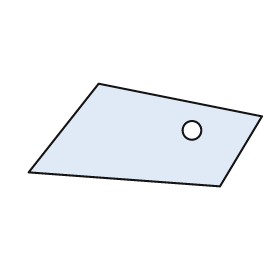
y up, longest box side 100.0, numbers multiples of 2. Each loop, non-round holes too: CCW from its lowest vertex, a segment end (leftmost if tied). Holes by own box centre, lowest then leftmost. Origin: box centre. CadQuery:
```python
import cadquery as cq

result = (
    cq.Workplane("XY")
    .moveTo(32.0, -22.0)
    .lineTo(50.0, 8.0)
    .lineTo(-20.0, 22.0)
    .lineTo(-50.0, -16.0)
    .close()
    .moveTo(20.0, 2.0)
    .circle(4.0)
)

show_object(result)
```